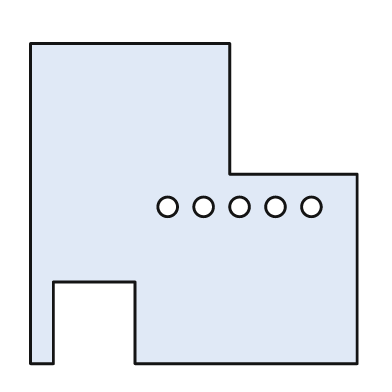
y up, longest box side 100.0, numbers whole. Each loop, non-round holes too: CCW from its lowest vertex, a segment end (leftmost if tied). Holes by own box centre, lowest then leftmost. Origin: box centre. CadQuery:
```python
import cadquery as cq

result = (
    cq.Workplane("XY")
    .moveTo(-50.0, -49.0)
    .lineTo(-43.0, -49.0)
    .lineTo(-43.0, -24.0)
    .lineTo(-18.0, -24.0)
    .lineTo(-18.0, -49.0)
    .lineTo(50.0, -49.0)
    .lineTo(50.0, 9.0)
    .lineTo(11.0, 9.0)
    .lineTo(11.0, 49.0)
    .lineTo(-50.0, 49.0)
    .close()
    .moveTo(-8.0, -1.0)
    .circle(3.0)
    .moveTo(3.0, -1.0)
    .circle(3.0)
    .moveTo(14.0, -1.0)
    .circle(3.0)
    .moveTo(25.0, -1.0)
    .circle(3.0)
    .moveTo(36.0, -1.0)
    .circle(3.0)
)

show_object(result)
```